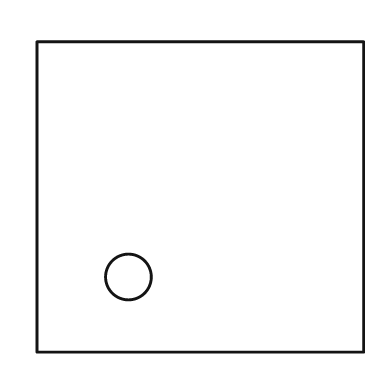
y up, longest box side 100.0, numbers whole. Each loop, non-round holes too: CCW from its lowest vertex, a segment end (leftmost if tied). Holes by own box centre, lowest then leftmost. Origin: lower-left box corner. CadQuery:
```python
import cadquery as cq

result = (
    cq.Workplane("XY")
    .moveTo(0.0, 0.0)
    .lineTo(100.0, 0.0)
    .lineTo(100.0, 95.0)
    .lineTo(0.0, 95.0)
    .close()
    .moveTo(28.0, 23.0)
    .circle(7.0)
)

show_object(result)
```